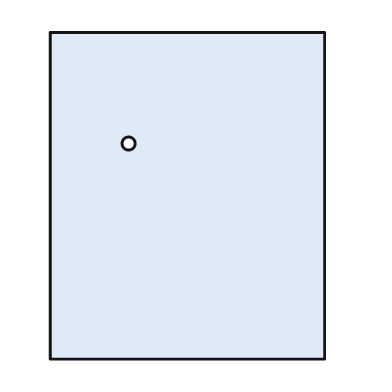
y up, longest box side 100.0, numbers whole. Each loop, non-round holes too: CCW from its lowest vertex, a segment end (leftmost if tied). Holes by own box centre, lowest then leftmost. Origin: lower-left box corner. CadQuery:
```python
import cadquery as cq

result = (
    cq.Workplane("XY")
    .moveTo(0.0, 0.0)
    .lineTo(84.0, 0.0)
    .lineTo(84.0, 100.0)
    .lineTo(0.0, 100.0)
    .close()
    .moveTo(24.0, 66.0)
    .circle(2.0)
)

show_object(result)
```